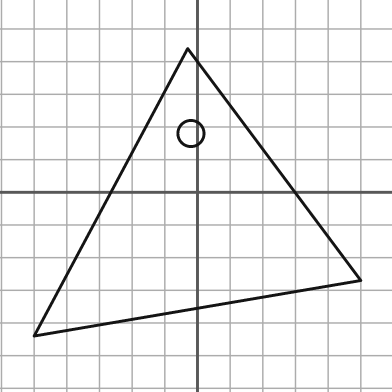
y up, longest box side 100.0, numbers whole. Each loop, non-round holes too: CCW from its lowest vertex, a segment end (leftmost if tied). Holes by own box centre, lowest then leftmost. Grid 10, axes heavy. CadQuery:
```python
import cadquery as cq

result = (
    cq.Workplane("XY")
    .moveTo(-50.0, -44.0)
    .lineTo(50.0, -27.0)
    .lineTo(-3.0, 44.0)
    .close()
    .moveTo(-2.0, 18.0)
    .circle(4.0)
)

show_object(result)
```